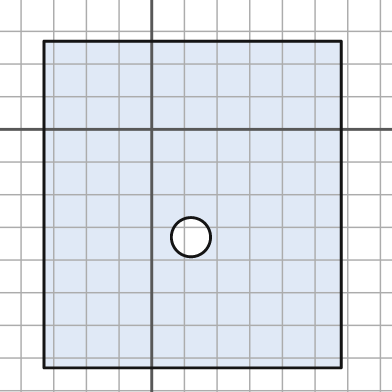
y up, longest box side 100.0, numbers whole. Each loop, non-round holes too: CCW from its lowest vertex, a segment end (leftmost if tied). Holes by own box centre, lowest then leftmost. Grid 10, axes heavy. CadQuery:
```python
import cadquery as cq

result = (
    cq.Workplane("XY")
    .moveTo(-33.0, -73.0)
    .lineTo(58.0, -73.0)
    .lineTo(58.0, 27.0)
    .lineTo(-33.0, 27.0)
    .close()
    .moveTo(12.0, -33.0)
    .circle(6.0)
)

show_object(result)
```